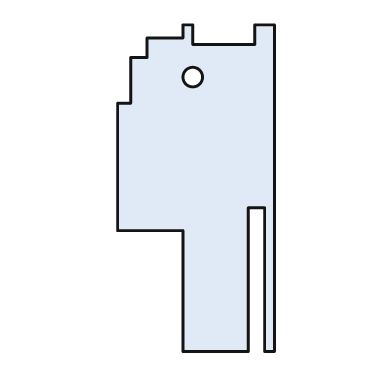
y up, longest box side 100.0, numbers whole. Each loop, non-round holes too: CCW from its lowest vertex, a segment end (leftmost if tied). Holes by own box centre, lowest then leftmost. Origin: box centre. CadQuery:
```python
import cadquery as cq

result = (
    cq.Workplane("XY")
    .moveTo(-4.0, -50.0)
    .lineTo(16.0, -50.0)
    .lineTo(16.0, -6.0)
    .lineTo(21.0, -6.0)
    .lineTo(21.0, -50.0)
    .lineTo(24.0, -50.0)
    .lineTo(24.0, 50.0)
    .lineTo(18.0, 50.0)
    .lineTo(18.0, 44.0)
    .lineTo(-1.0, 44.0)
    .lineTo(-1.0, 50.0)
    .lineTo(-4.0, 50.0)
    .lineTo(-4.0, 46.0)
    .lineTo(-15.0, 46.0)
    .lineTo(-15.0, 40.0)
    .lineTo(-20.0, 40.0)
    .lineTo(-20.0, 26.0)
    .lineTo(-24.0, 26.0)
    .lineTo(-24.0, -13.0)
    .lineTo(-4.0, -13.0)
    .close()
    .moveTo(-1.0, 34.0)
    .circle(3.0)
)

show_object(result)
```